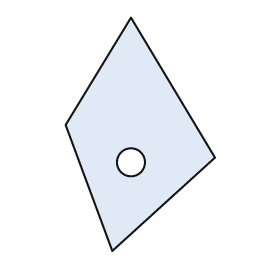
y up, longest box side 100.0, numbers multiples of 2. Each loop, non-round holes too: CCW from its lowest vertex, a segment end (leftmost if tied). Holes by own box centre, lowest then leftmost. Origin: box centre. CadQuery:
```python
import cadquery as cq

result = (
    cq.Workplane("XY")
    .moveTo(-12.0, -50.0)
    .lineTo(32.0, -10.0)
    .lineTo(-4.0, 50.0)
    .lineTo(-32.0, 4.0)
    .close()
    .moveTo(-4.0, -12.0)
    .circle(6.0)
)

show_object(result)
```